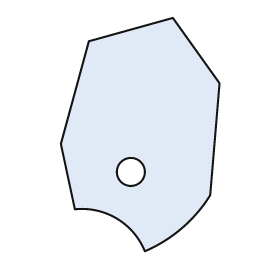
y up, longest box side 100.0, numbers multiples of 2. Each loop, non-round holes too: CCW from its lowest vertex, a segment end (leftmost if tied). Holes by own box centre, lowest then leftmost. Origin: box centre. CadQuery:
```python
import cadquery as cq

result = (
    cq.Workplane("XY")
    .moveTo(2.0, -50.0)
    .threePointArc((18.0, -40.0), (30.0, -26.0))
    .lineTo(34.0, 22.0)
    .lineTo(14.0, 50.0)
    .lineTo(-22.0, 40.0)
    .lineTo(-34.0, -4.0)
    .lineTo(-28.0, -32.0)
    .threePointArc((-10.0, -36.0), (2.0, -50.0))
    .close()
    .moveTo(-4.0, -16.0)
    .circle(6.0)
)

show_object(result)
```